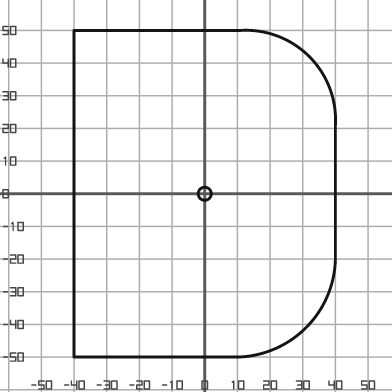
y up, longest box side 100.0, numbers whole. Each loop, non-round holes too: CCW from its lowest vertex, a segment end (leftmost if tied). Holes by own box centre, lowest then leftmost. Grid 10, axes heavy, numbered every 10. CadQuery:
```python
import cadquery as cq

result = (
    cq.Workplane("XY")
    .moveTo(-40.0, -50.0)
    .lineTo(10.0, -50.0)
    .threePointArc((31.0, -41.0), (40.0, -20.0))
    .lineTo(40.0, 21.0)
    .threePointArc((32.0, 42.0), (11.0, 50.0))
    .lineTo(-40.0, 50.0)
    .close()
    .moveTo(0.0, 0.0)
    .circle(2.0)
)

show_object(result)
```